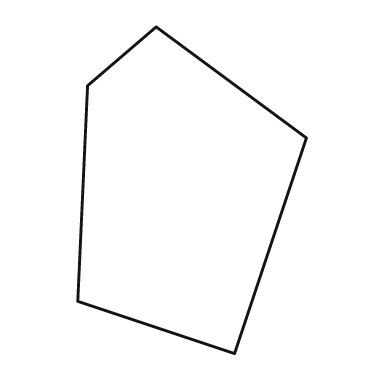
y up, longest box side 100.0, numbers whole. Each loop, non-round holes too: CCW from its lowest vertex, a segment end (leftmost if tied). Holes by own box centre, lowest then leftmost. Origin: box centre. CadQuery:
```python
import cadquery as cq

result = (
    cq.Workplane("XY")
    .moveTo(13.0, -50.0)
    .lineTo(35.0, 16.0)
    .lineTo(-11.0, 50.0)
    .lineTo(-32.0, 32.0)
    .lineTo(-35.0, -34.0)
    .close()
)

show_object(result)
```